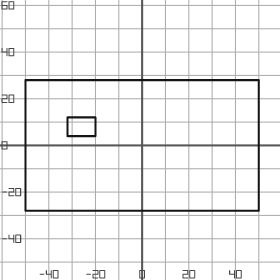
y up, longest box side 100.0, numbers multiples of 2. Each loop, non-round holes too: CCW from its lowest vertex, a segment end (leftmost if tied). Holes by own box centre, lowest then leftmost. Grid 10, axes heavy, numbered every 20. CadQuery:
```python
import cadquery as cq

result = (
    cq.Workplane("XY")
    .moveTo(-50.0, -28.0)
    .lineTo(50.0, -28.0)
    .lineTo(50.0, 28.0)
    .lineTo(-50.0, 28.0)
    .close()
    .moveTo(-32.0, 4.0)
    .lineTo(-20.0, 4.0)
    .lineTo(-20.0, 12.0)
    .lineTo(-32.0, 12.0)
    .close()
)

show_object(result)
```